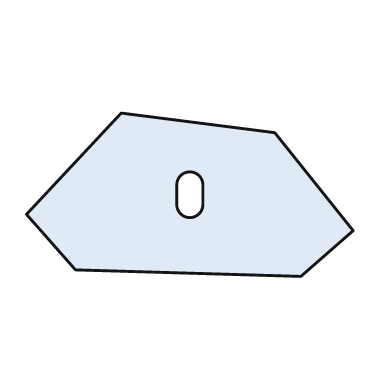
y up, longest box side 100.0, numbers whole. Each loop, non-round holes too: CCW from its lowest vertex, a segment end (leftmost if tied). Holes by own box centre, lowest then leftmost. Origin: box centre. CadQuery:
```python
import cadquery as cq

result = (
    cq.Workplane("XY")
    .moveTo(34.0, -25.0)
    .lineTo(50.0, -11.0)
    .lineTo(26.0, 19.0)
    .lineTo(-21.0, 25.0)
    .lineTo(-50.0, -6.0)
    .lineTo(-35.0, -23.0)
    .close()
    .moveTo(-4.0, -3.0)
    .threePointArc((0.0, -7.0), (4.0, -3.0))
    .lineTo(4.0, 3.0)
    .threePointArc((0.0, 7.0), (-4.0, 3.0))
    .close()
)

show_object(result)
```